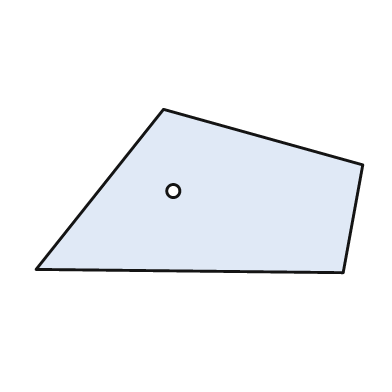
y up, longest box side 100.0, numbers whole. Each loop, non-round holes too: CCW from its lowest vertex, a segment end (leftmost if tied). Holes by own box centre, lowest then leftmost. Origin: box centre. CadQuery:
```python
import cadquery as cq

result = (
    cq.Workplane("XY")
    .moveTo(44.0, -25.0)
    .lineTo(50.0, 8.0)
    .lineTo(-11.0, 25.0)
    .lineTo(-50.0, -24.0)
    .close()
    .moveTo(-8.0, 0.0)
    .circle(2.0)
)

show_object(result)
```